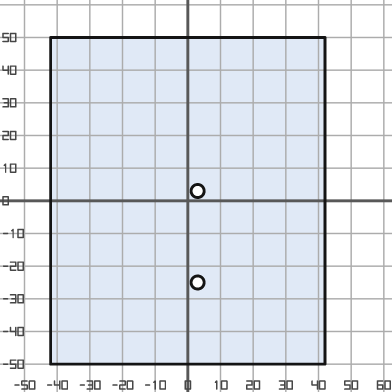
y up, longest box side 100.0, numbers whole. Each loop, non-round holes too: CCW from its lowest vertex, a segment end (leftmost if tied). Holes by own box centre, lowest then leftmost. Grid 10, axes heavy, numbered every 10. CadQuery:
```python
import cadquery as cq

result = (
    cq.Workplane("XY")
    .moveTo(-42.0, -50.0)
    .lineTo(42.0, -50.0)
    .lineTo(42.0, 50.0)
    .lineTo(-42.0, 50.0)
    .close()
    .moveTo(3.0, -25.0)
    .circle(2.0)
    .moveTo(3.0, 3.0)
    .circle(2.0)
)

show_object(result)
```